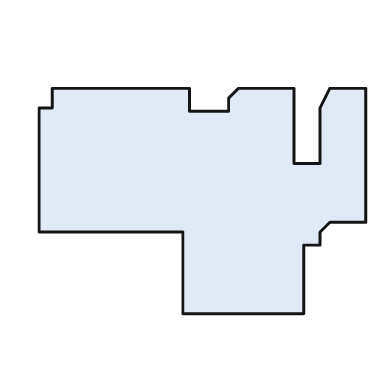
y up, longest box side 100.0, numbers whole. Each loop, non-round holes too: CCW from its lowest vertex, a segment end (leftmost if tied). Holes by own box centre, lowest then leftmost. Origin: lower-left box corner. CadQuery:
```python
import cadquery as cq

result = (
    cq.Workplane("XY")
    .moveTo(44.0, 0.0)
    .lineTo(81.0, 0.0)
    .lineTo(81.0, 21.0)
    .lineTo(86.0, 21.0)
    .lineTo(86.0, 25.0)
    .lineTo(89.0, 28.0)
    .lineTo(100.0, 28.0)
    .lineTo(100.0, 69.0)
    .lineTo(89.0, 69.0)
    .lineTo(86.0, 63.0)
    .lineTo(86.0, 46.0)
    .lineTo(78.0, 46.0)
    .lineTo(78.0, 69.0)
    .lineTo(61.0, 69.0)
    .lineTo(58.0, 66.0)
    .lineTo(58.0, 62.0)
    .lineTo(46.0, 62.0)
    .lineTo(46.0, 69.0)
    .lineTo(4.0, 69.0)
    .lineTo(4.0, 63.0)
    .lineTo(0.0, 63.0)
    .lineTo(0.0, 25.0)
    .lineTo(44.0, 25.0)
    .close()
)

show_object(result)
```